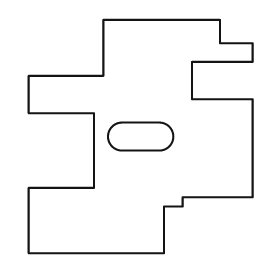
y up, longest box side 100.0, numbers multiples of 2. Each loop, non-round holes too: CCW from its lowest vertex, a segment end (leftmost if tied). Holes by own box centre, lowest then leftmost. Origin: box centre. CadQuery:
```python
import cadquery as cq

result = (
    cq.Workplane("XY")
    .moveTo(-48.0, -50.0)
    .lineTo(10.0, -50.0)
    .lineTo(10.0, -30.0)
    .lineTo(18.0, -30.0)
    .lineTo(18.0, -26.0)
    .lineTo(48.0, -26.0)
    .lineTo(48.0, 16.0)
    .lineTo(22.0, 16.0)
    .lineTo(22.0, 32.0)
    .lineTo(48.0, 32.0)
    .lineTo(48.0, 40.0)
    .lineTo(34.0, 40.0)
    .lineTo(34.0, 50.0)
    .lineTo(-16.0, 50.0)
    .lineTo(-16.0, 26.0)
    .lineTo(-48.0, 26.0)
    .lineTo(-48.0, 10.0)
    .lineTo(-20.0, 10.0)
    .lineTo(-20.0, -22.0)
    .lineTo(-48.0, -22.0)
    .close()
    .moveTo(-8.0, -6.0)
    .lineTo(8.0, -6.0)
    .threePointArc((14.0, 0.0), (8.0, 6.0))
    .lineTo(-8.0, 6.0)
    .threePointArc((-14.0, 0.0), (-8.0, -6.0))
    .close()
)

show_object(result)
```